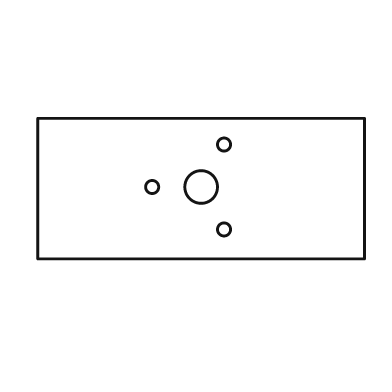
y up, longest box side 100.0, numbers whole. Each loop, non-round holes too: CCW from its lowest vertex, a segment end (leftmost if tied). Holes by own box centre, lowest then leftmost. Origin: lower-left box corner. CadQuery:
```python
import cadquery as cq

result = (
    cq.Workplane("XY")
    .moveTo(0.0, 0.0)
    .lineTo(100.0, 0.0)
    .lineTo(100.0, 43.0)
    .lineTo(0.0, 43.0)
    .close()
    .moveTo(57.0, 9.0)
    .circle(2.0)
    .moveTo(35.0, 22.0)
    .circle(2.0)
    .moveTo(50.0, 22.0)
    .circle(5.0)
    .moveTo(57.0, 35.0)
    .circle(2.0)
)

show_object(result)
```